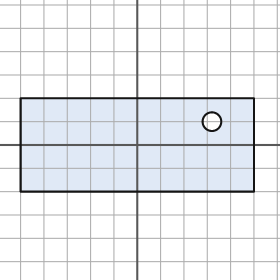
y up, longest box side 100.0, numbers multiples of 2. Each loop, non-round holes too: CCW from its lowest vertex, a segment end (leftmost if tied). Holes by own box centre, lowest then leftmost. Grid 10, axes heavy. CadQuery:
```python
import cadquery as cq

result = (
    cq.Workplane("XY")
    .moveTo(-50.0, -20.0)
    .lineTo(50.0, -20.0)
    .lineTo(50.0, 20.0)
    .lineTo(-50.0, 20.0)
    .close()
    .moveTo(32.0, 10.0)
    .circle(4.0)
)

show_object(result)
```